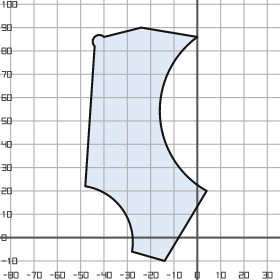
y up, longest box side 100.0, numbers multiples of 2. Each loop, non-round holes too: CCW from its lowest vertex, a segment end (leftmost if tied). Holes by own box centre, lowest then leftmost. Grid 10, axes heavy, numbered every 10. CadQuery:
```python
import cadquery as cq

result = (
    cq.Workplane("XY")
    .moveTo(-14.0, -10.0)
    .lineTo(4.0, 20.0)
    .threePointArc((-16.0, 52.0), (0.0, 86.0))
    .lineTo(-24.0, 90.0)
    .lineTo(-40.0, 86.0)
    .threePointArc((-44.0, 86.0), (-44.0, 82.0))
    .lineTo(-48.0, 22.0)
    .threePointArc((-32.0, 12.0), (-28.0, -6.0))
    .close()
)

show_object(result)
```